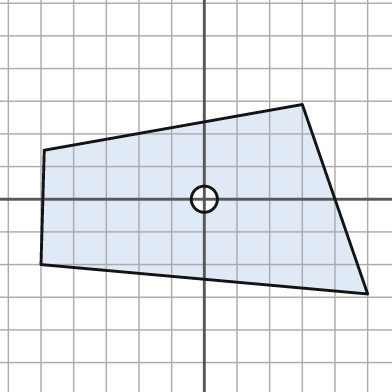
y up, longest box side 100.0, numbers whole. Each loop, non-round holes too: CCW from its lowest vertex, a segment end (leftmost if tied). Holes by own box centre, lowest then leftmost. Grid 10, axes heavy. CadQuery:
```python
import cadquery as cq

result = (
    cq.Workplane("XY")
    .moveTo(50.0, -29.0)
    .lineTo(30.0, 29.0)
    .lineTo(-49.0, 15.0)
    .lineTo(-50.0, -20.0)
    .close()
    .moveTo(0.0, 0.0)
    .circle(4.0)
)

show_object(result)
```